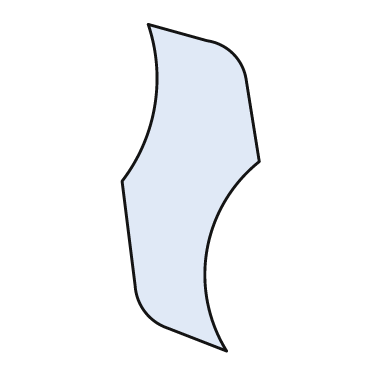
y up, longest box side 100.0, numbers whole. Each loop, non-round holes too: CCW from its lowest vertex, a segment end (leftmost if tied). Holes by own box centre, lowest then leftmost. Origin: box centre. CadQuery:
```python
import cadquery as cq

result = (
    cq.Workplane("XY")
    .moveTo(11.0, -50.0)
    .threePointArc((5.0, -19.0), (21.0, 8.0))
    .lineTo(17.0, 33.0)
    .threePointArc((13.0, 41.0), (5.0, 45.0))
    .lineTo(-13.0, 50.0)
    .threePointArc((-11.0, 25.0), (-21.0, 2.0))
    .lineTo(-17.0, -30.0)
    .threePointArc((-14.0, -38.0), (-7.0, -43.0))
    .close()
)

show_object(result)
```